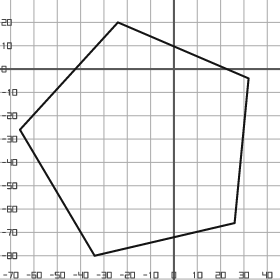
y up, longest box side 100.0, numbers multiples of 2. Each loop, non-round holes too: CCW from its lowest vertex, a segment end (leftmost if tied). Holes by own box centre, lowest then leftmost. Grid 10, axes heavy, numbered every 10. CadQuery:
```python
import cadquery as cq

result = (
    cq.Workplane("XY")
    .moveTo(-34.0, -80.0)
    .lineTo(26.0, -66.0)
    .lineTo(32.0, -4.0)
    .lineTo(-24.0, 20.0)
    .lineTo(-66.0, -26.0)
    .close()
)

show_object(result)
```